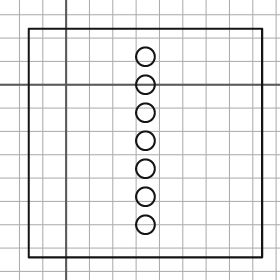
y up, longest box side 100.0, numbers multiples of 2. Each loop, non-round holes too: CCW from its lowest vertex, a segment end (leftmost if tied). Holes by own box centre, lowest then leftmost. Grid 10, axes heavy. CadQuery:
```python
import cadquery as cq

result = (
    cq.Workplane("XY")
    .moveTo(-16.0, -74.0)
    .lineTo(84.0, -74.0)
    .lineTo(84.0, 24.0)
    .lineTo(-16.0, 24.0)
    .close()
    .moveTo(34.0, -60.0)
    .circle(4.0)
    .moveTo(34.0, -48.0)
    .circle(4.0)
    .moveTo(34.0, -36.0)
    .circle(4.0)
    .moveTo(34.0, -24.0)
    .circle(4.0)
    .moveTo(34.0, -12.0)
    .circle(4.0)
    .moveTo(34.0, 0.0)
    .circle(4.0)
    .moveTo(34.0, 12.0)
    .circle(4.0)
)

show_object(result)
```